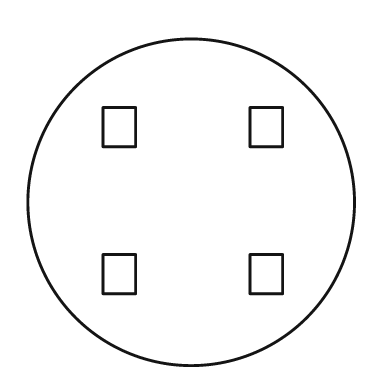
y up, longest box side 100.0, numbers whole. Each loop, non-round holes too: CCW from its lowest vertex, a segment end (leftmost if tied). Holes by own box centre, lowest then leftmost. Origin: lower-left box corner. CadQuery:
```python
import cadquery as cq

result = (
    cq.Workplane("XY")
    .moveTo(50.0, 50.0)
    .circle(50.0)
    .moveTo(23.0, 22.0)
    .lineTo(33.0, 22.0)
    .lineTo(33.0, 34.0)
    .lineTo(23.0, 34.0)
    .close()
    .moveTo(68.0, 22.0)
    .lineTo(78.0, 22.0)
    .lineTo(78.0, 34.0)
    .lineTo(68.0, 34.0)
    .close()
    .moveTo(23.0, 67.0)
    .lineTo(33.0, 67.0)
    .lineTo(33.0, 79.0)
    .lineTo(23.0, 79.0)
    .close()
    .moveTo(68.0, 67.0)
    .lineTo(78.0, 67.0)
    .lineTo(78.0, 79.0)
    .lineTo(68.0, 79.0)
    .close()
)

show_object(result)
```